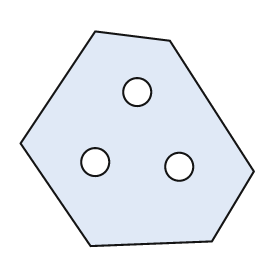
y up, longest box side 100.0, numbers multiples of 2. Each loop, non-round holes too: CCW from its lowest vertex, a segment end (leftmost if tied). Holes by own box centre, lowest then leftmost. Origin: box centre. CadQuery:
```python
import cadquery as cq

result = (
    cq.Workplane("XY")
    .moveTo(-20.0, -46.0)
    .lineTo(32.0, -44.0)
    .lineTo(50.0, -14.0)
    .lineTo(14.0, 42.0)
    .lineTo(-18.0, 46.0)
    .lineTo(-50.0, -2.0)
    .close()
    .moveTo(18.0, -12.0)
    .circle(6.0)
    .moveTo(-18.0, -10.0)
    .circle(6.0)
    .moveTo(0.0, 20.0)
    .circle(6.0)
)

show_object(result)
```